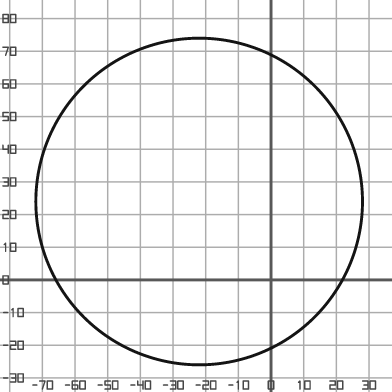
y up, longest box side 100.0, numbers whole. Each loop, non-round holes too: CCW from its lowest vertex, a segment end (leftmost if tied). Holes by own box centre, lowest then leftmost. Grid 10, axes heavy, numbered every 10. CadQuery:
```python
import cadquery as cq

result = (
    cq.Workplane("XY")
    .moveTo(-22.0, 24.0)
    .circle(50.0)
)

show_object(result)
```